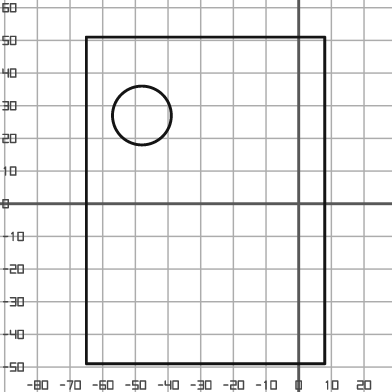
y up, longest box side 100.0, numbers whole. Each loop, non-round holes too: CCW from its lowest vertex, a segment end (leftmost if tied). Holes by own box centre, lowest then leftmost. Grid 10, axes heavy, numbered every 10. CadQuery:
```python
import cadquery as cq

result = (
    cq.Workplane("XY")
    .moveTo(-65.0, -49.0)
    .lineTo(8.0, -49.0)
    .lineTo(8.0, 51.0)
    .lineTo(-65.0, 51.0)
    .close()
    .moveTo(-48.0, 27.0)
    .circle(9.0)
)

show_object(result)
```